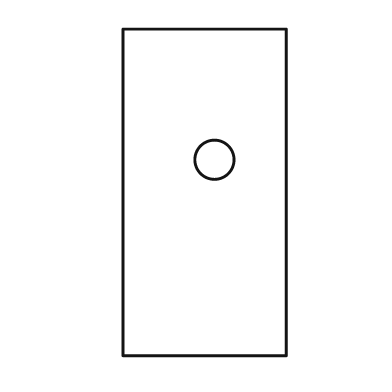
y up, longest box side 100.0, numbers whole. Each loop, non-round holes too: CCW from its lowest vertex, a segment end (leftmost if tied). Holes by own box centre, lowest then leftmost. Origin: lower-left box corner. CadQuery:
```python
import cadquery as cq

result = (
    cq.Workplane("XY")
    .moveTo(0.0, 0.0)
    .lineTo(50.0, 0.0)
    .lineTo(50.0, 100.0)
    .lineTo(0.0, 100.0)
    .close()
    .moveTo(28.0, 60.0)
    .circle(6.0)
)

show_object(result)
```